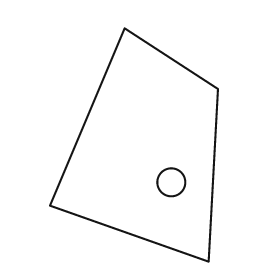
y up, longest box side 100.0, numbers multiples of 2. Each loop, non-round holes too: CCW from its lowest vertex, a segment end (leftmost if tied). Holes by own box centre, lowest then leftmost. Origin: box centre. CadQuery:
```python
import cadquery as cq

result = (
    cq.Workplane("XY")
    .moveTo(32.0, -50.0)
    .lineTo(36.0, 24.0)
    .lineTo(-4.0, 50.0)
    .lineTo(-36.0, -26.0)
    .close()
    .moveTo(16.0, -16.0)
    .circle(6.0)
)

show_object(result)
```